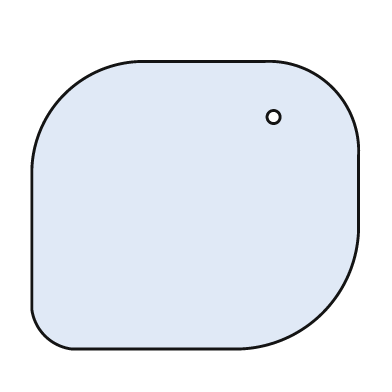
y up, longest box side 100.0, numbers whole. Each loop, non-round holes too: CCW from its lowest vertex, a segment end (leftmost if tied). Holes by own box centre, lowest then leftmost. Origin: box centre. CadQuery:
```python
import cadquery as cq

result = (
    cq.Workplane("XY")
    .moveTo(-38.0, -44.0)
    .lineTo(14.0, -44.0)
    .threePointArc((39.0, -33.0), (50.0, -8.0))
    .lineTo(50.0, 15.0)
    .threePointArc((42.0, 36.0), (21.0, 44.0))
    .lineTo(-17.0, 44.0)
    .threePointArc((-40.0, 34.0), (-50.0, 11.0))
    .lineTo(-50.0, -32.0)
    .threePointArc((-46.0, -40.0), (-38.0, -44.0))
    .close()
    .moveTo(24.0, 27.0)
    .circle(2.0)
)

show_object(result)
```